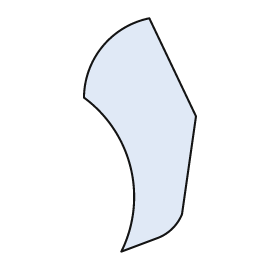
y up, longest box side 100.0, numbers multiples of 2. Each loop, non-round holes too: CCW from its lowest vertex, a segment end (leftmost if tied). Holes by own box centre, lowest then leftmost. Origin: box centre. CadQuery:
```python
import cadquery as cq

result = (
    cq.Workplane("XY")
    .moveTo(-8.0, -50.0)
    .lineTo(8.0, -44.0)
    .threePointArc((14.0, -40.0), (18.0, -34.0))
    .lineTo(24.0, 8.0)
    .lineTo(4.0, 50.0)
    .threePointArc((-16.0, 38.0), (-24.0, 16.0))
    .threePointArc((-4.0, -14.0), (-8.0, -50.0))
    .close()
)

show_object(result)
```